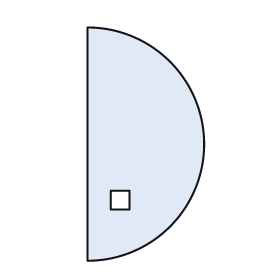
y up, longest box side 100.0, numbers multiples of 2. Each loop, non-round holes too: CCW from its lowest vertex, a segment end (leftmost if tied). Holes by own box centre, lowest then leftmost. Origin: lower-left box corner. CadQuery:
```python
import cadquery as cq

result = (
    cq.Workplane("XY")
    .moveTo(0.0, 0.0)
    .threePointArc((50.0, 50.0), (0.0, 100.0))
    .close()
    .moveTo(10.0, 22.0)
    .lineTo(18.0, 22.0)
    .lineTo(18.0, 30.0)
    .lineTo(10.0, 30.0)
    .close()
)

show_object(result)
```